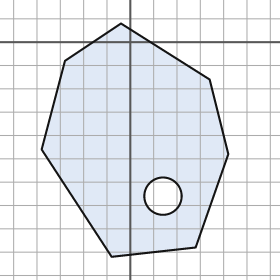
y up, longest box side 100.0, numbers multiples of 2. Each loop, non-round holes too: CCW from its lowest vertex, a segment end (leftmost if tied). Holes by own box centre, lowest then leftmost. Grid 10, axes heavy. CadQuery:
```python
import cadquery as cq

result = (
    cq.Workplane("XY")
    .moveTo(-8.0, -92.0)
    .lineTo(28.0, -88.0)
    .lineTo(42.0, -48.0)
    .lineTo(34.0, -16.0)
    .lineTo(-4.0, 8.0)
    .lineTo(-28.0, -8.0)
    .lineTo(-38.0, -46.0)
    .close()
    .moveTo(14.0, -66.0)
    .circle(8.0)
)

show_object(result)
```